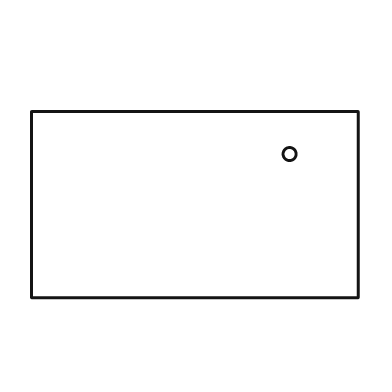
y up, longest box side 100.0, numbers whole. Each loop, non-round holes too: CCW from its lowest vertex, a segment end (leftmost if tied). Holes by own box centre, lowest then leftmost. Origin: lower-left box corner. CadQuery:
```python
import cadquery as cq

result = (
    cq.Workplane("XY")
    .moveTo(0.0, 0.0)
    .lineTo(100.0, 0.0)
    .lineTo(100.0, 57.0)
    .lineTo(0.0, 57.0)
    .close()
    .moveTo(79.0, 44.0)
    .circle(2.0)
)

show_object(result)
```